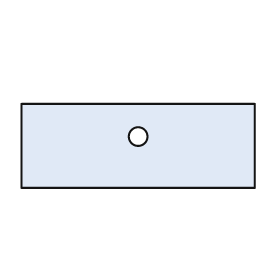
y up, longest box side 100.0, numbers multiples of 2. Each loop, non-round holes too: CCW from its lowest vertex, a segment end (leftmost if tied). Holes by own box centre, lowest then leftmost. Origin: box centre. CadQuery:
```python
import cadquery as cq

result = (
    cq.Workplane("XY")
    .moveTo(-50.0, -18.0)
    .lineTo(50.0, -18.0)
    .lineTo(50.0, 18.0)
    .lineTo(-50.0, 18.0)
    .close()
    .moveTo(0.0, 4.0)
    .circle(4.0)
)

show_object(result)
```